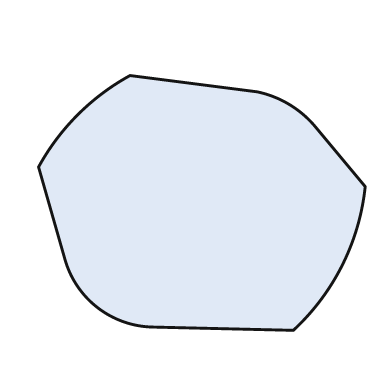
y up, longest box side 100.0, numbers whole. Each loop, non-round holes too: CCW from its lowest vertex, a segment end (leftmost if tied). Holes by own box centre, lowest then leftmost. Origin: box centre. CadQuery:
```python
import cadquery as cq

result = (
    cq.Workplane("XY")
    .moveTo(28.0, -39.0)
    .threePointArc((43.0, -19.0), (50.0, 5.0))
    .lineTo(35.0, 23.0)
    .threePointArc((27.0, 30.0), (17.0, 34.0))
    .lineTo(-22.0, 39.0)
    .threePointArc((-38.0, 27.0), (-50.0, 11.0))
    .lineTo(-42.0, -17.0)
    .threePointArc((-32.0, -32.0), (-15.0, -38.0))
    .close()
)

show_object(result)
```